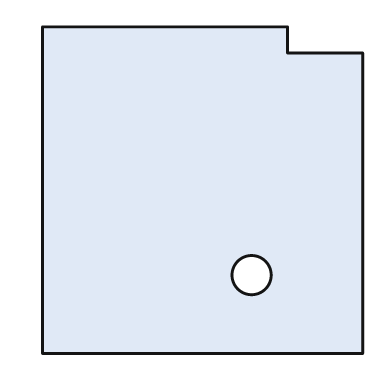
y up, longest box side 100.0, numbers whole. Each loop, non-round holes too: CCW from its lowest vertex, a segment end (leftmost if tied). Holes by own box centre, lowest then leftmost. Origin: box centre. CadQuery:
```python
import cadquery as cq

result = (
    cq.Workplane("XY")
    .moveTo(-49.0, -50.0)
    .lineTo(49.0, -50.0)
    .lineTo(49.0, 42.0)
    .lineTo(26.0, 42.0)
    .lineTo(26.0, 50.0)
    .lineTo(-49.0, 50.0)
    .close()
    .moveTo(15.0, -26.0)
    .circle(6.0)
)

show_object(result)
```